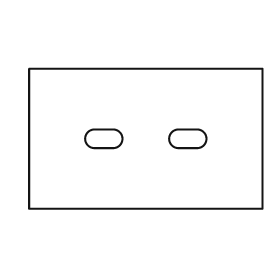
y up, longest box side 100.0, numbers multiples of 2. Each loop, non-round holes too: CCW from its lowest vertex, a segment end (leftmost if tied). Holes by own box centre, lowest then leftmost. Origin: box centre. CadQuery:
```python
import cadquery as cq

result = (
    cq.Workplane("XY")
    .moveTo(-50.0, -30.0)
    .lineTo(50.0, -30.0)
    .lineTo(50.0, 30.0)
    .lineTo(-50.0, 30.0)
    .close()
    .moveTo(-22.0, -4.0)
    .lineTo(-14.0, -4.0)
    .threePointArc((-10.0, 0.0), (-14.0, 4.0))
    .lineTo(-22.0, 4.0)
    .threePointArc((-26.0, 0.0), (-22.0, -4.0))
    .close()
    .moveTo(14.0, -4.0)
    .lineTo(22.0, -4.0)
    .threePointArc((26.0, 0.0), (22.0, 4.0))
    .lineTo(14.0, 4.0)
    .threePointArc((10.0, 0.0), (14.0, -4.0))
    .close()
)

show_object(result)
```